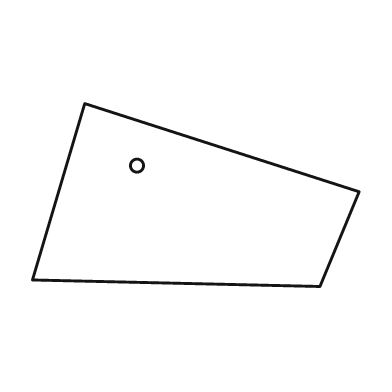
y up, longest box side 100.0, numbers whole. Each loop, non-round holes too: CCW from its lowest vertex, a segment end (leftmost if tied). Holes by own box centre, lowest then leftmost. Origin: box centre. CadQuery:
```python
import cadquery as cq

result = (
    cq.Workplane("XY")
    .moveTo(38.0, -28.0)
    .lineTo(50.0, 1.0)
    .lineTo(-34.0, 28.0)
    .lineTo(-50.0, -26.0)
    .close()
    .moveTo(-18.0, 9.0)
    .circle(2.0)
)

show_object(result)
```